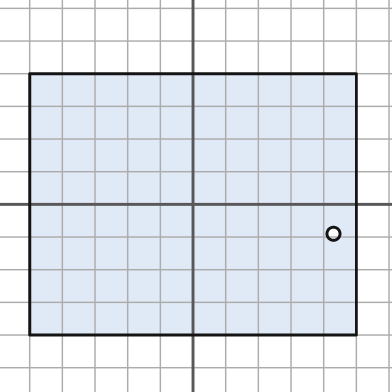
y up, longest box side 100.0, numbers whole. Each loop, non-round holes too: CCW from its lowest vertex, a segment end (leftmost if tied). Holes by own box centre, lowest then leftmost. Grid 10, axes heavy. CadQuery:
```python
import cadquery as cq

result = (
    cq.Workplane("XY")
    .moveTo(-50.0, -40.0)
    .lineTo(50.0, -40.0)
    .lineTo(50.0, 40.0)
    .lineTo(-50.0, 40.0)
    .close()
    .moveTo(43.0, -9.0)
    .circle(2.0)
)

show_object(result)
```